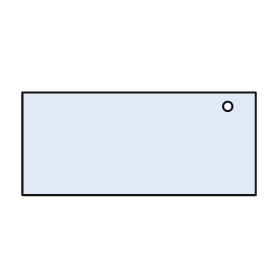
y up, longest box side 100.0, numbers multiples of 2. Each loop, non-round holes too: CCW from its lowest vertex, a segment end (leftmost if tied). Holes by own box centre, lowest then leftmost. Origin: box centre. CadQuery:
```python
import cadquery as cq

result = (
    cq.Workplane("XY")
    .moveTo(-50.0, -22.0)
    .lineTo(50.0, -22.0)
    .lineTo(50.0, 22.0)
    .lineTo(-50.0, 22.0)
    .close()
    .moveTo(38.0, 16.0)
    .circle(2.0)
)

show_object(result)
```